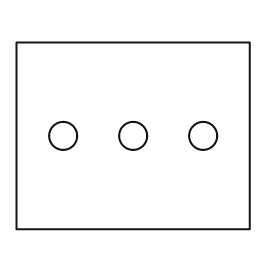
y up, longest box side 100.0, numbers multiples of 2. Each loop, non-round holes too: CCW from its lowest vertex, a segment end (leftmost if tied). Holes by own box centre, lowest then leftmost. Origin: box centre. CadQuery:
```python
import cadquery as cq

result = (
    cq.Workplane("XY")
    .moveTo(-50.0, -40.0)
    .lineTo(50.0, -40.0)
    .lineTo(50.0, 40.0)
    .lineTo(-50.0, 40.0)
    .close()
    .moveTo(-30.0, 0.0)
    .circle(6.0)
    .moveTo(0.0, 0.0)
    .circle(6.0)
    .moveTo(30.0, 0.0)
    .circle(6.0)
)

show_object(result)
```